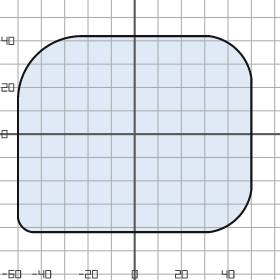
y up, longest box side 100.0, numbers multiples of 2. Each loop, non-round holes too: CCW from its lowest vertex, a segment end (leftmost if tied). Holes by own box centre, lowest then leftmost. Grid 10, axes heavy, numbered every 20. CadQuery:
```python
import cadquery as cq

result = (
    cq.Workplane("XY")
    .moveTo(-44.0, -42.0)
    .lineTo(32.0, -42.0)
    .threePointArc((44.0, -36.0), (50.0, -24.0))
    .lineTo(50.0, 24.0)
    .threePointArc((44.0, 36.0), (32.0, 42.0))
    .lineTo(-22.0, 42.0)
    .threePointArc((-42.0, 34.0), (-50.0, 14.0))
    .lineTo(-50.0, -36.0)
    .threePointArc((-48.0, -40.0), (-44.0, -42.0))
    .close()
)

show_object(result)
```